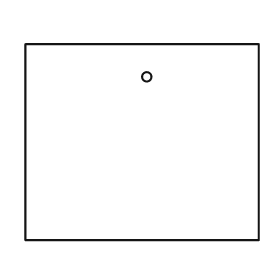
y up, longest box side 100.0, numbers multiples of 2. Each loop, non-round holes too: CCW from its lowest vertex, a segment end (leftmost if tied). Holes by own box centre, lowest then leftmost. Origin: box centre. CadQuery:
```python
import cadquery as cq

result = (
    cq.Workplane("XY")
    .moveTo(-50.0, -42.0)
    .lineTo(50.0, -42.0)
    .lineTo(50.0, 42.0)
    .lineTo(-50.0, 42.0)
    .close()
    .moveTo(2.0, 28.0)
    .circle(2.0)
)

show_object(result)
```